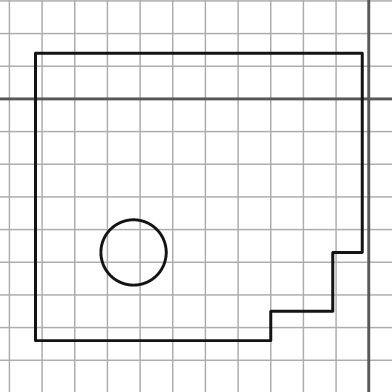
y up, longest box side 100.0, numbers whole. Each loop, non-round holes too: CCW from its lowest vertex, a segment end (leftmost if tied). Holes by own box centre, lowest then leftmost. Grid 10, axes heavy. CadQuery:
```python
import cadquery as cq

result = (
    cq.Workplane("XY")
    .moveTo(-102.0, -74.0)
    .lineTo(-30.0, -74.0)
    .lineTo(-30.0, -65.0)
    .lineTo(-11.0, -65.0)
    .lineTo(-11.0, -47.0)
    .lineTo(-2.0, -47.0)
    .lineTo(-2.0, 14.0)
    .lineTo(-102.0, 14.0)
    .close()
    .moveTo(-72.0, -47.0)
    .circle(10.0)
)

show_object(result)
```